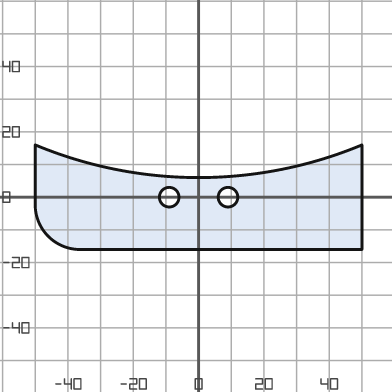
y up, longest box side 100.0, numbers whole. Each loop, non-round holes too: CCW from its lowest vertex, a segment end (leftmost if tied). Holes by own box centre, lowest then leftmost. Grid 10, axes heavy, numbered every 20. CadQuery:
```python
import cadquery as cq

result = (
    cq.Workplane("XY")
    .moveTo(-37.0, -16.0)
    .lineTo(50.0, -16.0)
    .lineTo(50.0, 16.0)
    .threePointArc((0.0, 6.0), (-50.0, 16.0))
    .lineTo(-50.0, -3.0)
    .threePointArc((-46.0, -12.0), (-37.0, -16.0))
    .close()
    .moveTo(-9.0, 0.0)
    .circle(3.0)
    .moveTo(9.0, 0.0)
    .circle(3.0)
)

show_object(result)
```